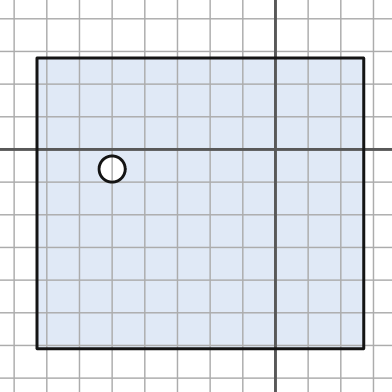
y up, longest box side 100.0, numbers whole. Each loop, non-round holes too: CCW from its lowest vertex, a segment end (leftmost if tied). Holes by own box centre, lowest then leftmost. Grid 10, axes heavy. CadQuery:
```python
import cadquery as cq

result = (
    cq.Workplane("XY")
    .moveTo(-73.0, -61.0)
    .lineTo(27.0, -61.0)
    .lineTo(27.0, 28.0)
    .lineTo(-73.0, 28.0)
    .close()
    .moveTo(-50.0, -6.0)
    .circle(4.0)
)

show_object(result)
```